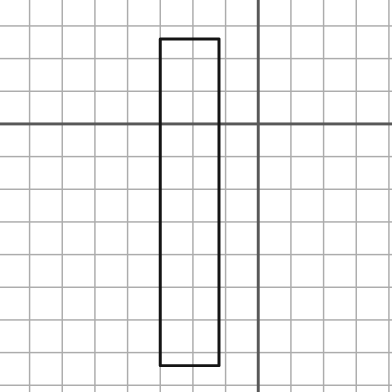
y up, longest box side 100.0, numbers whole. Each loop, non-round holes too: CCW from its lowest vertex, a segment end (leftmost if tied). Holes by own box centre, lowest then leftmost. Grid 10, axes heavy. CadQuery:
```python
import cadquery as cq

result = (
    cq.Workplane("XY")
    .moveTo(-30.0, -74.0)
    .lineTo(-12.0, -74.0)
    .lineTo(-12.0, 26.0)
    .lineTo(-30.0, 26.0)
    .close()
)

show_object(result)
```